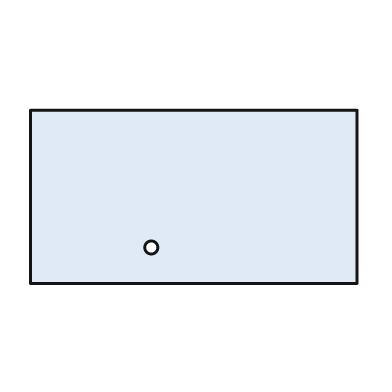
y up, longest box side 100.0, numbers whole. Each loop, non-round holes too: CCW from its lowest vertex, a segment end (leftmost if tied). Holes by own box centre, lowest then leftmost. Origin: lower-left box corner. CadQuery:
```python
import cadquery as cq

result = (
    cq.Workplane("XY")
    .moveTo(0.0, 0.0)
    .lineTo(100.0, 0.0)
    .lineTo(100.0, 53.0)
    .lineTo(0.0, 53.0)
    .close()
    .moveTo(37.0, 11.0)
    .circle(2.0)
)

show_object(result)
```